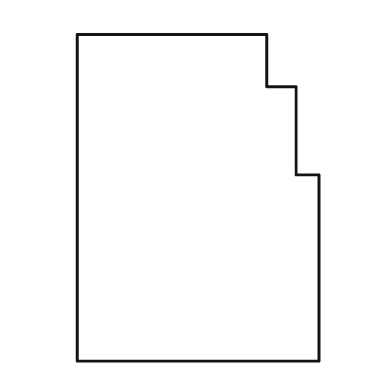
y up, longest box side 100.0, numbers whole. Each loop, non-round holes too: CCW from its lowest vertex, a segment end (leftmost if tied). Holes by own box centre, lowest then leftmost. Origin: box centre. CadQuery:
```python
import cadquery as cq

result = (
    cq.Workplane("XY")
    .moveTo(-37.0, -50.0)
    .lineTo(37.0, -50.0)
    .lineTo(37.0, 7.0)
    .lineTo(30.0, 7.0)
    .lineTo(30.0, 34.0)
    .lineTo(21.0, 34.0)
    .lineTo(21.0, 50.0)
    .lineTo(-37.0, 50.0)
    .close()
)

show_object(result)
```